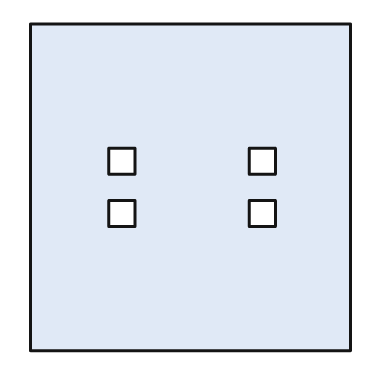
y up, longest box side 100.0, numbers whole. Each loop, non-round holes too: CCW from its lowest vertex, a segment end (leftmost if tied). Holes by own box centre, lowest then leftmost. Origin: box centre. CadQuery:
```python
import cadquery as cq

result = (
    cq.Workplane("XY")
    .moveTo(-49.0, -50.0)
    .lineTo(49.0, -50.0)
    .lineTo(49.0, 50.0)
    .lineTo(-49.0, 50.0)
    .close()
    .moveTo(-25.0, -12.0)
    .lineTo(-17.0, -12.0)
    .lineTo(-17.0, -4.0)
    .lineTo(-25.0, -4.0)
    .close()
    .moveTo(18.0, -12.0)
    .lineTo(26.0, -12.0)
    .lineTo(26.0, -4.0)
    .lineTo(18.0, -4.0)
    .close()
    .moveTo(-25.0, 4.0)
    .lineTo(-17.0, 4.0)
    .lineTo(-17.0, 12.0)
    .lineTo(-25.0, 12.0)
    .close()
    .moveTo(18.0, 4.0)
    .lineTo(26.0, 4.0)
    .lineTo(26.0, 12.0)
    .lineTo(18.0, 12.0)
    .close()
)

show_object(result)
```